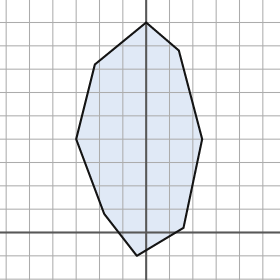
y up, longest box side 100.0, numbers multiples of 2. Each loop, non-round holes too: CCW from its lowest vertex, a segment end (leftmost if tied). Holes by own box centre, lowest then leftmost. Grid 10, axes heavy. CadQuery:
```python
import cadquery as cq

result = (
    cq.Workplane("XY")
    .moveTo(-4.0, -10.0)
    .lineTo(16.0, 2.0)
    .lineTo(24.0, 40.0)
    .lineTo(14.0, 78.0)
    .lineTo(0.0, 90.0)
    .lineTo(-22.0, 72.0)
    .lineTo(-30.0, 40.0)
    .lineTo(-18.0, 8.0)
    .close()
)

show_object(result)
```